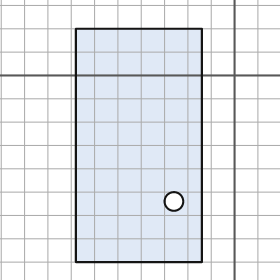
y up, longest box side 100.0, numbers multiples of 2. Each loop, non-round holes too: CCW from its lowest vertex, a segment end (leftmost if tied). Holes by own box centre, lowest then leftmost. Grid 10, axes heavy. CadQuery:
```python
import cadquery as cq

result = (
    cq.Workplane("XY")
    .moveTo(-68.0, -80.0)
    .lineTo(-14.0, -80.0)
    .lineTo(-14.0, 20.0)
    .lineTo(-68.0, 20.0)
    .close()
    .moveTo(-26.0, -54.0)
    .circle(4.0)
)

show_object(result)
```